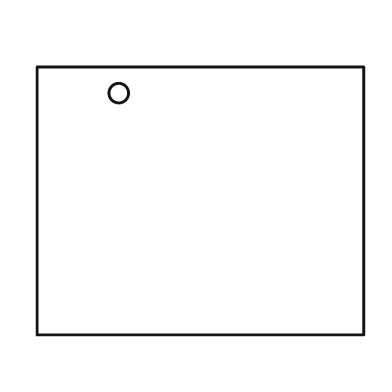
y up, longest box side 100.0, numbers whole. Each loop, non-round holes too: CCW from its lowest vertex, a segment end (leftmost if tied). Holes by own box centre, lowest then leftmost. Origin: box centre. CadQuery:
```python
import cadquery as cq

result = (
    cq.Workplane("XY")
    .moveTo(-50.0, -41.0)
    .lineTo(50.0, -41.0)
    .lineTo(50.0, 41.0)
    .lineTo(-50.0, 41.0)
    .close()
    .moveTo(-25.0, 33.0)
    .circle(3.0)
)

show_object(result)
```